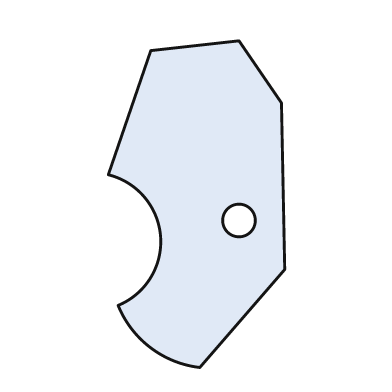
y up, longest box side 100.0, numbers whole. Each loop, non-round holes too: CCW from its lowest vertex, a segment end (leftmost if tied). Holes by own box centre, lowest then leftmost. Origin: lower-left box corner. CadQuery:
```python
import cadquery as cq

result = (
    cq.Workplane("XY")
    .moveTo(28.0, 0.0)
    .lineTo(54.0, 30.0)
    .lineTo(53.0, 81.0)
    .lineTo(40.0, 100.0)
    .lineTo(13.0, 97.0)
    .lineTo(0.0, 59.0)
    .threePointArc((16.0, 40.0), (3.0, 19.0))
    .threePointArc((13.0, 6.0), (28.0, 0.0))
    .close()
    .moveTo(40.0, 45.0)
    .circle(5.0)
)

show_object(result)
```